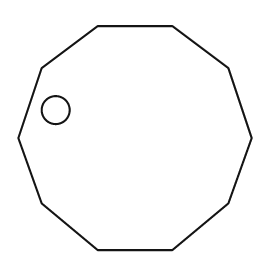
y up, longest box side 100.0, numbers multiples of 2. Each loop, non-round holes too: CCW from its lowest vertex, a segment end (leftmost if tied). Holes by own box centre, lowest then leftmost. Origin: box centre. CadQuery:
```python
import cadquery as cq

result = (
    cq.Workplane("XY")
    .moveTo(-16.0, -48.0)
    .lineTo(16.0, -48.0)
    .lineTo(40.0, -28.0)
    .lineTo(50.0, 0.0)
    .lineTo(40.0, 30.0)
    .lineTo(16.0, 48.0)
    .lineTo(-16.0, 48.0)
    .lineTo(-40.0, 30.0)
    .lineTo(-50.0, 0.0)
    .lineTo(-40.0, -28.0)
    .close()
    .moveTo(-34.0, 12.0)
    .circle(6.0)
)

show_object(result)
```